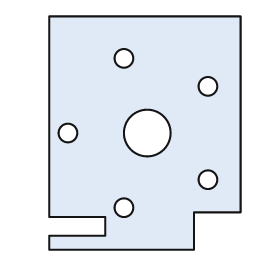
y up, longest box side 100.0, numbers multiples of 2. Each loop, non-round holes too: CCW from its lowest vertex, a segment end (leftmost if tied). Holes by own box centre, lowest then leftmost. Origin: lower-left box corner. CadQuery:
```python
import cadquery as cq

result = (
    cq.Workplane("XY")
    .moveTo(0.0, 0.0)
    .lineTo(62.0, 0.0)
    .lineTo(62.0, 16.0)
    .lineTo(82.0, 16.0)
    .lineTo(82.0, 100.0)
    .lineTo(0.0, 100.0)
    .lineTo(0.0, 14.0)
    .lineTo(24.0, 14.0)
    .lineTo(24.0, 6.0)
    .lineTo(0.0, 6.0)
    .close()
    .moveTo(32.0, 18.0)
    .circle(4.0)
    .moveTo(68.0, 30.0)
    .circle(4.0)
    .moveTo(8.0, 50.0)
    .circle(4.0)
    .moveTo(42.0, 50.0)
    .circle(10.0)
    .moveTo(68.0, 70.0)
    .circle(4.0)
    .moveTo(32.0, 82.0)
    .circle(4.0)
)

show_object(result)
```